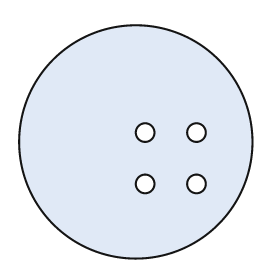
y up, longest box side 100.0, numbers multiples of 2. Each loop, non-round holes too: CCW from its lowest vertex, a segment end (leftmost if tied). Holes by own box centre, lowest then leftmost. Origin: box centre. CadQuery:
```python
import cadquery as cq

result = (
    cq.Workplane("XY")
    .moveTo(0.0, 0.0)
    .circle(50.0)
    .moveTo(4.0, -18.0)
    .circle(4.0)
    .moveTo(26.0, -18.0)
    .circle(4.0)
    .moveTo(4.0, 4.0)
    .circle(4.0)
    .moveTo(26.0, 4.0)
    .circle(4.0)
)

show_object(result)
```